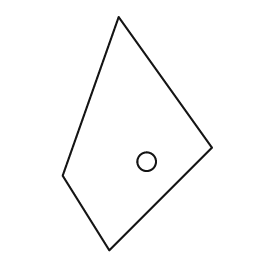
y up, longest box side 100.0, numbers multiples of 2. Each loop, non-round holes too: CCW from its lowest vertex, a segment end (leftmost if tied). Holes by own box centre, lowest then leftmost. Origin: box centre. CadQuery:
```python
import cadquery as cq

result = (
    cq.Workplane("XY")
    .moveTo(-12.0, -50.0)
    .lineTo(32.0, -6.0)
    .lineTo(-8.0, 50.0)
    .lineTo(-32.0, -18.0)
    .close()
    .moveTo(4.0, -12.0)
    .circle(4.0)
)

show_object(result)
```